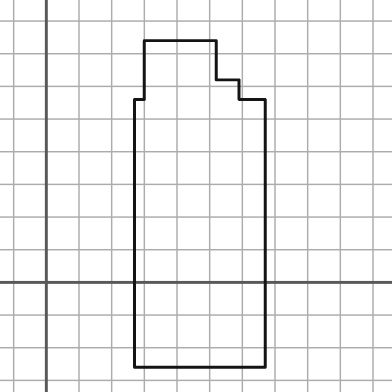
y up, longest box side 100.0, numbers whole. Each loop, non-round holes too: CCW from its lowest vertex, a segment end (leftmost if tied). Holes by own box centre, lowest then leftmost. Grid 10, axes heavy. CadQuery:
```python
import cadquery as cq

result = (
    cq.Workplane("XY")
    .moveTo(27.0, -26.0)
    .lineTo(67.0, -26.0)
    .lineTo(67.0, 56.0)
    .lineTo(59.0, 56.0)
    .lineTo(59.0, 62.0)
    .lineTo(52.0, 62.0)
    .lineTo(52.0, 74.0)
    .lineTo(30.0, 74.0)
    .lineTo(30.0, 56.0)
    .lineTo(27.0, 56.0)
    .close()
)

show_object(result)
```